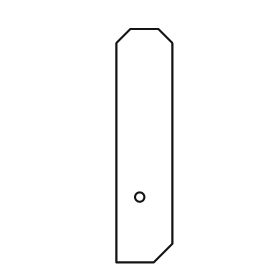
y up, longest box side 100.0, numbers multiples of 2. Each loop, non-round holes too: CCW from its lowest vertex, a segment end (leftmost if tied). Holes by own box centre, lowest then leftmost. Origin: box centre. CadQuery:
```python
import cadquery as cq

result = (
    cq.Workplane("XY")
    .moveTo(-12.0, -50.0)
    .lineTo(4.0, -50.0)
    .lineTo(12.0, -42.0)
    .lineTo(12.0, 44.0)
    .lineTo(6.0, 50.0)
    .lineTo(-6.0, 50.0)
    .lineTo(-12.0, 44.0)
    .close()
    .moveTo(-2.0, -22.0)
    .circle(2.0)
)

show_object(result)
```